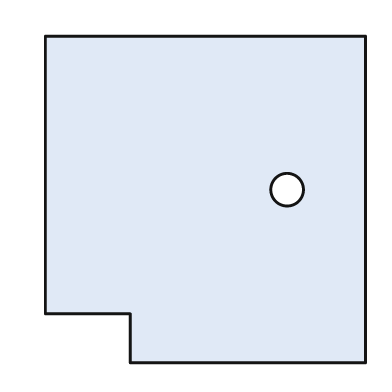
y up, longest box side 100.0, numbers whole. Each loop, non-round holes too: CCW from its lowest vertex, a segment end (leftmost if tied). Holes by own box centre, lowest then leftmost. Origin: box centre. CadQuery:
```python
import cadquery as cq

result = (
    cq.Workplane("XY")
    .moveTo(-23.0, -50.0)
    .lineTo(49.0, -50.0)
    .lineTo(49.0, 50.0)
    .lineTo(-49.0, 50.0)
    .lineTo(-49.0, -35.0)
    .lineTo(-23.0, -35.0)
    .close()
    .moveTo(25.0, 3.0)
    .circle(5.0)
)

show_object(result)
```